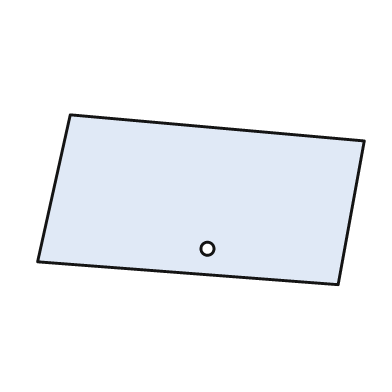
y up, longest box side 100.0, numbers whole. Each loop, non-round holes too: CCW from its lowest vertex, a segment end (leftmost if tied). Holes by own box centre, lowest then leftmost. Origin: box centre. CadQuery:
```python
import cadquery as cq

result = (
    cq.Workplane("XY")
    .moveTo(42.0, -26.0)
    .lineTo(50.0, 18.0)
    .lineTo(-40.0, 26.0)
    .lineTo(-50.0, -19.0)
    .close()
    .moveTo(2.0, -15.0)
    .circle(2.0)
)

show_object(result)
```